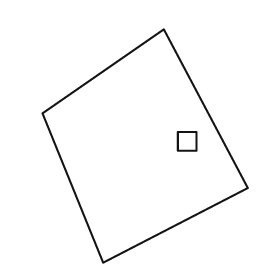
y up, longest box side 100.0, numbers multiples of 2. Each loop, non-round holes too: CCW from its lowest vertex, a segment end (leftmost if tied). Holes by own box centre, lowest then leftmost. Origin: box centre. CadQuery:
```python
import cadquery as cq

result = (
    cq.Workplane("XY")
    .moveTo(-18.0, -50.0)
    .lineTo(44.0, -18.0)
    .lineTo(8.0, 50.0)
    .lineTo(-44.0, 14.0)
    .close()
    .moveTo(14.0, -2.0)
    .lineTo(22.0, -2.0)
    .lineTo(22.0, 6.0)
    .lineTo(14.0, 6.0)
    .close()
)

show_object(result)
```